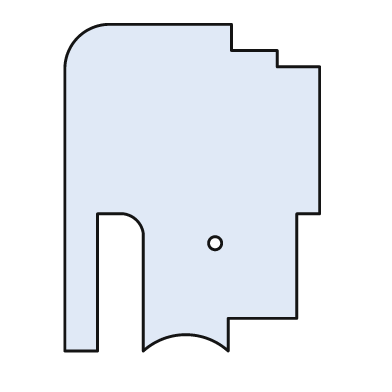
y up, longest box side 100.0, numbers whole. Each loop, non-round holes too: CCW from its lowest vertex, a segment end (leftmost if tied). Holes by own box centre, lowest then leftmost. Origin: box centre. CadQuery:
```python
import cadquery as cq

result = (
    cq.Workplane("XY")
    .moveTo(-39.0, -50.0)
    .lineTo(-29.0, -50.0)
    .lineTo(-29.0, -8.0)
    .lineTo(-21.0, -8.0)
    .threePointArc((-17.0, -10.0), (-15.0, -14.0))
    .lineTo(-15.0, -50.0)
    .threePointArc((-2.0, -45.0), (11.0, -50.0))
    .lineTo(11.0, -40.0)
    .lineTo(32.0, -40.0)
    .lineTo(32.0, -8.0)
    .lineTo(39.0, -8.0)
    .lineTo(39.0, 37.0)
    .lineTo(26.0, 37.0)
    .lineTo(26.0, 42.0)
    .lineTo(12.0, 42.0)
    .lineTo(12.0, 50.0)
    .lineTo(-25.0, 50.0)
    .threePointArc((-35.0, 46.0), (-39.0, 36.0))
    .close()
    .moveTo(7.0, -17.0)
    .circle(2.0)
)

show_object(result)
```